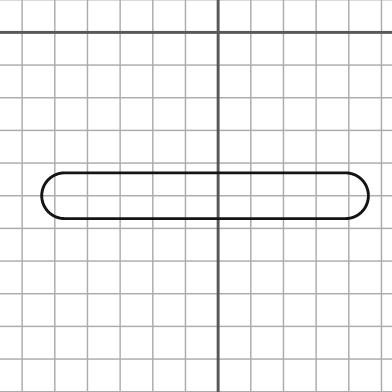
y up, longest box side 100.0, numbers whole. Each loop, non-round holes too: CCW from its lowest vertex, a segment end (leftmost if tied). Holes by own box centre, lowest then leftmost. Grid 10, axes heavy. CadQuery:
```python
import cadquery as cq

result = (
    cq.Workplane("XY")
    .moveTo(-47.0, -57.0)
    .lineTo(39.0, -57.0)
    .threePointArc((46.0, -50.0), (39.0, -43.0))
    .lineTo(-47.0, -43.0)
    .threePointArc((-54.0, -50.0), (-47.0, -57.0))
    .close()
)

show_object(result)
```